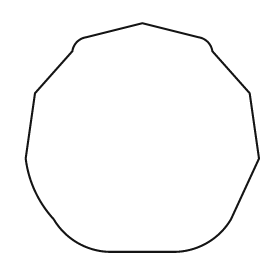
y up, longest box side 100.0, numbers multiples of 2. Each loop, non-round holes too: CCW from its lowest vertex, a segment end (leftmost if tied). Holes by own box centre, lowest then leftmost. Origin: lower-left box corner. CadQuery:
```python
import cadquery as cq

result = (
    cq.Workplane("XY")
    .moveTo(36.0, 0.0)
    .lineTo(64.0, 0.0)
    .threePointArc((78.0, 4.0), (88.0, 14.0))
    .lineTo(100.0, 40.0)
    .lineTo(96.0, 68.0)
    .lineTo(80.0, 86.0)
    .threePointArc((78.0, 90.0), (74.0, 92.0))
    .lineTo(50.0, 98.0)
    .lineTo(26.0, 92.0)
    .threePointArc((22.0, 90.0), (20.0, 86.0))
    .lineTo(4.0, 68.0)
    .lineTo(0.0, 40.0)
    .threePointArc((4.0, 26.0), (12.0, 14.0))
    .threePointArc((22.0, 4.0), (36.0, 0.0))
    .close()
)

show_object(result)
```